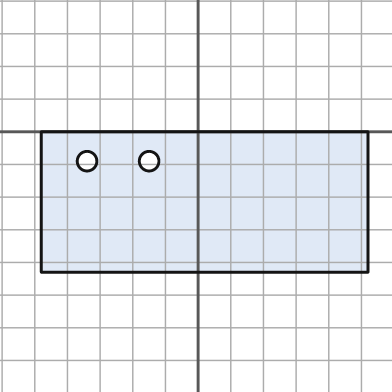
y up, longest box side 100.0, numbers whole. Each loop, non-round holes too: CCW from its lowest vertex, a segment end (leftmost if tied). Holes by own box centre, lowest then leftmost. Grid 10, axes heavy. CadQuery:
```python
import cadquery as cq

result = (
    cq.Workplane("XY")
    .moveTo(-48.0, -43.0)
    .lineTo(52.0, -43.0)
    .lineTo(52.0, 0.0)
    .lineTo(-48.0, 0.0)
    .close()
    .moveTo(-34.0, -9.0)
    .circle(3.0)
    .moveTo(-15.0, -9.0)
    .circle(3.0)
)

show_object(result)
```